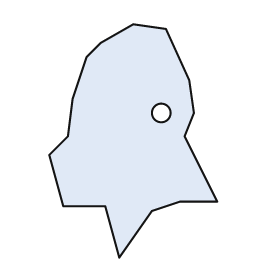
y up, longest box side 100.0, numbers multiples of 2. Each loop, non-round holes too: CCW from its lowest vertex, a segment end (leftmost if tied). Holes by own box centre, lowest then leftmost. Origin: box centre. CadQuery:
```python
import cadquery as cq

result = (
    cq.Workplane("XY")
    .moveTo(-6.0, -50.0)
    .lineTo(8.0, -30.0)
    .lineTo(20.0, -26.0)
    .lineTo(36.0, -26.0)
    .lineTo(22.0, 2.0)
    .lineTo(26.0, 12.0)
    .lineTo(24.0, 26.0)
    .lineTo(14.0, 48.0)
    .lineTo(0.0, 50.0)
    .lineTo(-14.0, 42.0)
    .lineTo(-20.0, 36.0)
    .lineTo(-26.0, 18.0)
    .lineTo(-28.0, 2.0)
    .lineTo(-36.0, -6.0)
    .lineTo(-30.0, -28.0)
    .lineTo(-12.0, -28.0)
    .close()
    .moveTo(12.0, 12.0)
    .circle(4.0)
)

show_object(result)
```